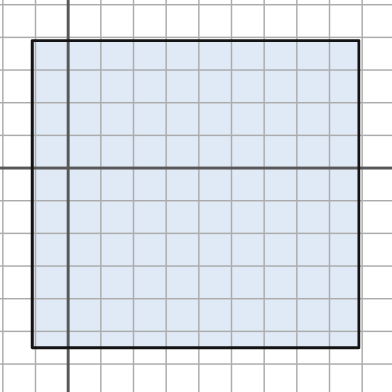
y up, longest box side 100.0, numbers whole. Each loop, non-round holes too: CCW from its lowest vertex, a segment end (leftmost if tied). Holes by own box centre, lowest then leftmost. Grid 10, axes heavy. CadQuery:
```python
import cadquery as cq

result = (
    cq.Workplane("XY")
    .moveTo(-11.0, -55.0)
    .lineTo(89.0, -55.0)
    .lineTo(89.0, 39.0)
    .lineTo(-11.0, 39.0)
    .close()
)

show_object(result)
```